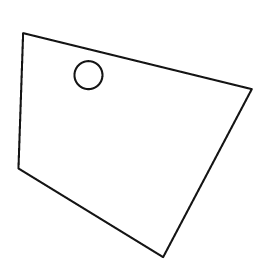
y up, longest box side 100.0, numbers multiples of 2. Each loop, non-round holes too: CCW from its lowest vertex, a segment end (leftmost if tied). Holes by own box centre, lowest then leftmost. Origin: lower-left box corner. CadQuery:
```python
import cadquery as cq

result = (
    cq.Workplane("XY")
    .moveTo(62.0, 0.0)
    .lineTo(100.0, 72.0)
    .lineTo(2.0, 96.0)
    .lineTo(0.0, 38.0)
    .close()
    .moveTo(30.0, 78.0)
    .circle(6.0)
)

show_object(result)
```